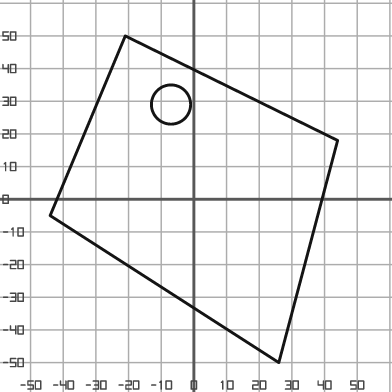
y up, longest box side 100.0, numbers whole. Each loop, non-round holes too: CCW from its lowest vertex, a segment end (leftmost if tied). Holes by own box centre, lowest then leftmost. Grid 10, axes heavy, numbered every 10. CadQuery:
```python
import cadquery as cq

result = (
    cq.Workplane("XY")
    .moveTo(26.0, -50.0)
    .lineTo(44.0, 18.0)
    .lineTo(-21.0, 50.0)
    .lineTo(-44.0, -5.0)
    .close()
    .moveTo(-7.0, 29.0)
    .circle(6.0)
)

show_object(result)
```